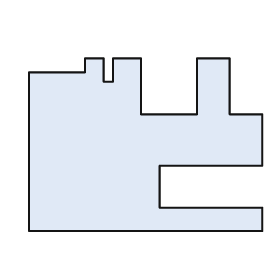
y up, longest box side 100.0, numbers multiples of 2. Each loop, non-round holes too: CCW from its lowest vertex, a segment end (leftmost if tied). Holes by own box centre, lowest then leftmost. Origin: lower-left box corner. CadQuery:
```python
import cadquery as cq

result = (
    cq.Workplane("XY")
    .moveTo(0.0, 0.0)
    .lineTo(100.0, 0.0)
    .lineTo(100.0, 10.0)
    .lineTo(56.0, 10.0)
    .lineTo(56.0, 28.0)
    .lineTo(100.0, 28.0)
    .lineTo(100.0, 50.0)
    .lineTo(86.0, 50.0)
    .lineTo(86.0, 74.0)
    .lineTo(72.0, 74.0)
    .lineTo(72.0, 50.0)
    .lineTo(48.0, 50.0)
    .lineTo(48.0, 74.0)
    .lineTo(36.0, 74.0)
    .lineTo(36.0, 64.0)
    .lineTo(32.0, 64.0)
    .lineTo(32.0, 74.0)
    .lineTo(24.0, 74.0)
    .lineTo(24.0, 68.0)
    .lineTo(0.0, 68.0)
    .close()
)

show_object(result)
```